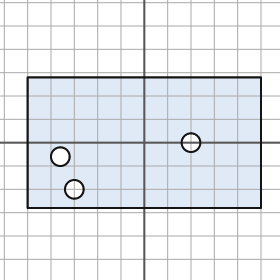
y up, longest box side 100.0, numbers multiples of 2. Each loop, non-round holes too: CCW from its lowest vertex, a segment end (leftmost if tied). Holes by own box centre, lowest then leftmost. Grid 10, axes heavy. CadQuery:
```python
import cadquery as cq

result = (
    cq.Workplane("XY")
    .moveTo(-50.0, -28.0)
    .lineTo(50.0, -28.0)
    .lineTo(50.0, 28.0)
    .lineTo(-50.0, 28.0)
    .close()
    .moveTo(-30.0, -20.0)
    .circle(4.0)
    .moveTo(-36.0, -6.0)
    .circle(4.0)
    .moveTo(20.0, 0.0)
    .circle(4.0)
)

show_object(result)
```